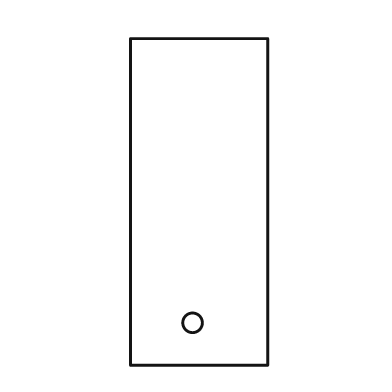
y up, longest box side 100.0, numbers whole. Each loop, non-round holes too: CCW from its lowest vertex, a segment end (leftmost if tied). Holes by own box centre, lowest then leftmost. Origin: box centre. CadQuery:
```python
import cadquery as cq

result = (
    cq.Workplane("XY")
    .moveTo(-21.0, -50.0)
    .lineTo(21.0, -50.0)
    .lineTo(21.0, 50.0)
    .lineTo(-21.0, 50.0)
    .close()
    .moveTo(-2.0, -37.0)
    .circle(3.0)
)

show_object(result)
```